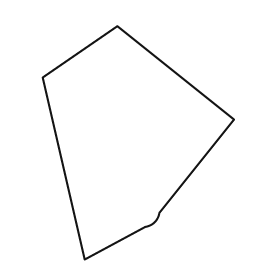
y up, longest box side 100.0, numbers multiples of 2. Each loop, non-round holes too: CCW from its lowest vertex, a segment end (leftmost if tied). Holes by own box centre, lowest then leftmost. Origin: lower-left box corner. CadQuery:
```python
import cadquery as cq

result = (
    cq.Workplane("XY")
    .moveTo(18.0, 0.0)
    .lineTo(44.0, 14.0)
    .threePointArc((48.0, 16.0), (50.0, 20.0))
    .lineTo(82.0, 60.0)
    .lineTo(32.0, 100.0)
    .lineTo(0.0, 78.0)
    .close()
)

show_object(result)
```